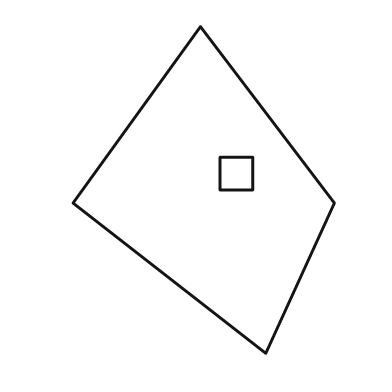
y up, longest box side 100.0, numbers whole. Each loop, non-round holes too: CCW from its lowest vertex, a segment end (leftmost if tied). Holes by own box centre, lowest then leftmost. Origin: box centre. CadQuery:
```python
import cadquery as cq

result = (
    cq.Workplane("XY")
    .moveTo(19.0, -50.0)
    .lineTo(40.0, -4.0)
    .lineTo(-1.0, 50.0)
    .lineTo(-40.0, -4.0)
    .close()
    .moveTo(5.0, 0.0)
    .lineTo(15.0, 0.0)
    .lineTo(15.0, 10.0)
    .lineTo(5.0, 10.0)
    .close()
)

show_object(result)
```